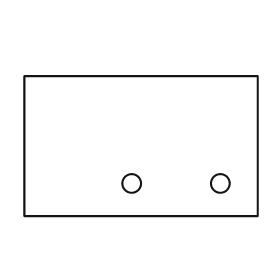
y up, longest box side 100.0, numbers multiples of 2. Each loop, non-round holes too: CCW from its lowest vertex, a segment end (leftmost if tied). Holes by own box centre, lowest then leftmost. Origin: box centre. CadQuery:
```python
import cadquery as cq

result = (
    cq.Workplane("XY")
    .moveTo(-50.0, -30.0)
    .lineTo(50.0, -30.0)
    .lineTo(50.0, 30.0)
    .lineTo(-50.0, 30.0)
    .close()
    .moveTo(-4.0, -16.0)
    .circle(4.0)
    .moveTo(34.0, -16.0)
    .circle(4.0)
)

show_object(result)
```